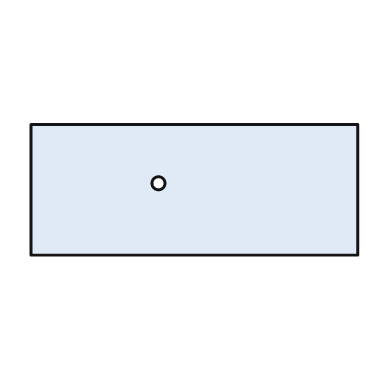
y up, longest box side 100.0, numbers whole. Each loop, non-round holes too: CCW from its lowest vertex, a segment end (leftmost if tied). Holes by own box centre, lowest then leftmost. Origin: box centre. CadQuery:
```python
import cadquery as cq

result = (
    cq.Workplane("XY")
    .moveTo(-50.0, -20.0)
    .lineTo(50.0, -20.0)
    .lineTo(50.0, 20.0)
    .lineTo(-50.0, 20.0)
    .close()
    .moveTo(-11.0, 2.0)
    .circle(2.0)
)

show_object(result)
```